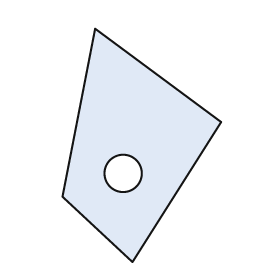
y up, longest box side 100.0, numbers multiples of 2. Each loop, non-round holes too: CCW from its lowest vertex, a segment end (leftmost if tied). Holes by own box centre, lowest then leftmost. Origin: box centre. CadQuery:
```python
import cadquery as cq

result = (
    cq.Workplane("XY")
    .moveTo(-4.0, -50.0)
    .lineTo(34.0, 10.0)
    .lineTo(-20.0, 50.0)
    .lineTo(-34.0, -22.0)
    .close()
    .moveTo(-8.0, -12.0)
    .circle(8.0)
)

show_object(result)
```